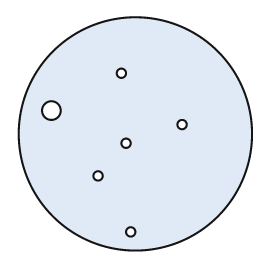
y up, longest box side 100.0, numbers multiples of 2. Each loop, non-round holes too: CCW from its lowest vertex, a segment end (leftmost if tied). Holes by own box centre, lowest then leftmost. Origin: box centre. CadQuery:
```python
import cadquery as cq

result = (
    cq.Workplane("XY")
    .moveTo(0.0, 0.0)
    .circle(50.0)
    .moveTo(-2.0, -42.0)
    .circle(2.0)
    .moveTo(-16.0, -18.0)
    .circle(2.0)
    .moveTo(-4.0, -4.0)
    .circle(2.0)
    .moveTo(20.0, 4.0)
    .circle(2.0)
    .moveTo(-36.0, 10.0)
    .circle(4.0)
    .moveTo(-6.0, 26.0)
    .circle(2.0)
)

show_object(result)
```